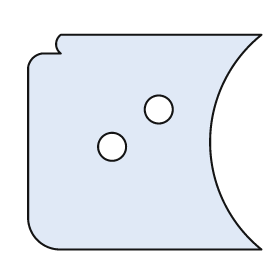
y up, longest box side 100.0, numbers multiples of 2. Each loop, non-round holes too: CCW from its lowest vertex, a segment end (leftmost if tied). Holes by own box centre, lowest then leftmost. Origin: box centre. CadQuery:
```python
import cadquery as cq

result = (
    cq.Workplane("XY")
    .moveTo(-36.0, -46.0)
    .lineTo(50.0, -46.0)
    .threePointArc((28.0, 0.0), (50.0, 46.0))
    .lineTo(-36.0, 46.0)
    .threePointArc((-38.0, 42.0), (-36.0, 38.0))
    .lineTo(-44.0, 38.0)
    .threePointArc((-48.0, 36.0), (-50.0, 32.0))
    .lineTo(-50.0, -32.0)
    .threePointArc((-46.0, -42.0), (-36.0, -46.0))
    .close()
    .moveTo(-14.0, -2.0)
    .circle(6.0)
    .moveTo(6.0, 14.0)
    .circle(6.0)
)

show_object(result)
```